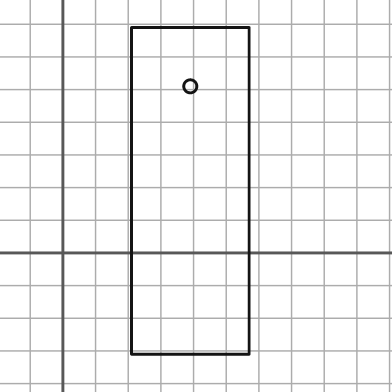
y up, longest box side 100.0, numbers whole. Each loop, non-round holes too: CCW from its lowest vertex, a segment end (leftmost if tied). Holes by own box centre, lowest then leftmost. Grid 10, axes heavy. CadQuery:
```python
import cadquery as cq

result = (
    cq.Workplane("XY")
    .moveTo(21.0, -31.0)
    .lineTo(57.0, -31.0)
    .lineTo(57.0, 69.0)
    .lineTo(21.0, 69.0)
    .close()
    .moveTo(39.0, 51.0)
    .circle(2.0)
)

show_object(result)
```